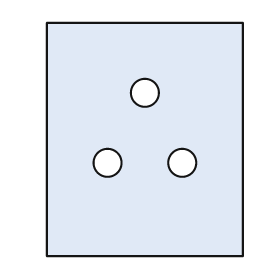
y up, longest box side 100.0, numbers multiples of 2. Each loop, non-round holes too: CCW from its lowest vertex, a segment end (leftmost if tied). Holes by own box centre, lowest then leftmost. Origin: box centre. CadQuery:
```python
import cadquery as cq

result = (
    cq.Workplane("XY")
    .moveTo(-42.0, -50.0)
    .lineTo(42.0, -50.0)
    .lineTo(42.0, 50.0)
    .lineTo(-42.0, 50.0)
    .close()
    .moveTo(-16.0, -10.0)
    .circle(6.0)
    .moveTo(16.0, -10.0)
    .circle(6.0)
    .moveTo(0.0, 20.0)
    .circle(6.0)
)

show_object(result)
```